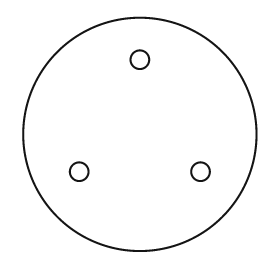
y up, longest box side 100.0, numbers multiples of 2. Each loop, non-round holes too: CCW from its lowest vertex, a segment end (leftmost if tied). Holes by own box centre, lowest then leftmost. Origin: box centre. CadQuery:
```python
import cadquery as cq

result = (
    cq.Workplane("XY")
    .moveTo(0.0, 0.0)
    .circle(50.0)
    .moveTo(-26.0, -16.0)
    .circle(4.0)
    .moveTo(26.0, -16.0)
    .circle(4.0)
    .moveTo(0.0, 32.0)
    .circle(4.0)
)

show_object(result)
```